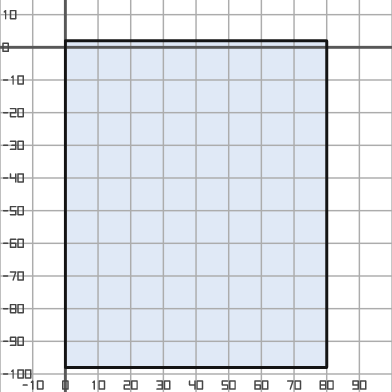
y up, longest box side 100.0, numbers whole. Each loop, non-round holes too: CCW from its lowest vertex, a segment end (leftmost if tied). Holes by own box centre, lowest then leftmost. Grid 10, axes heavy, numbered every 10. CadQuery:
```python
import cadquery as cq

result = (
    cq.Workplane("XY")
    .moveTo(0.0, -98.0)
    .lineTo(80.0, -98.0)
    .lineTo(80.0, 2.0)
    .lineTo(0.0, 2.0)
    .close()
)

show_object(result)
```